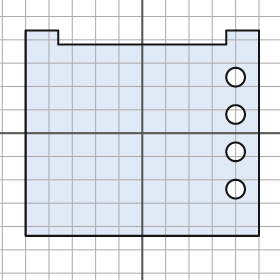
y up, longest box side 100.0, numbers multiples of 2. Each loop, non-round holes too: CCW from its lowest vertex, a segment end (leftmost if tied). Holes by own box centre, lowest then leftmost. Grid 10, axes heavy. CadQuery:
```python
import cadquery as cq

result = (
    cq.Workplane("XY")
    .moveTo(-50.0, -44.0)
    .lineTo(50.0, -44.0)
    .lineTo(50.0, 44.0)
    .lineTo(36.0, 44.0)
    .lineTo(36.0, 38.0)
    .lineTo(-36.0, 38.0)
    .lineTo(-36.0, 44.0)
    .lineTo(-50.0, 44.0)
    .close()
    .moveTo(40.0, -24.0)
    .circle(4.0)
    .moveTo(40.0, -8.0)
    .circle(4.0)
    .moveTo(40.0, 8.0)
    .circle(4.0)
    .moveTo(40.0, 24.0)
    .circle(4.0)
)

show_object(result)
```